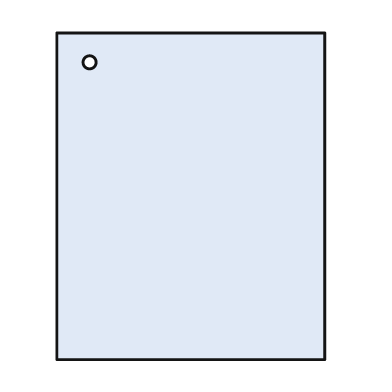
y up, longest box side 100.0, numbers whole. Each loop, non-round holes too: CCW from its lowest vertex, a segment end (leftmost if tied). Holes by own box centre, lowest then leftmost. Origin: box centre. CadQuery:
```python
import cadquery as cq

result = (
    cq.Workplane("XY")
    .moveTo(-41.0, -50.0)
    .lineTo(41.0, -50.0)
    .lineTo(41.0, 50.0)
    .lineTo(-41.0, 50.0)
    .close()
    .moveTo(-31.0, 41.0)
    .circle(2.0)
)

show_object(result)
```